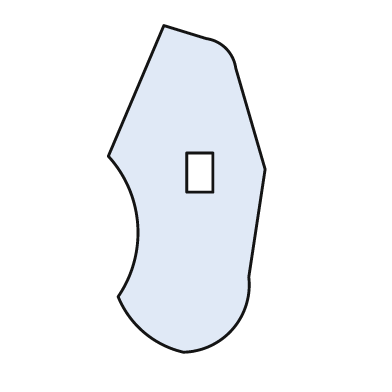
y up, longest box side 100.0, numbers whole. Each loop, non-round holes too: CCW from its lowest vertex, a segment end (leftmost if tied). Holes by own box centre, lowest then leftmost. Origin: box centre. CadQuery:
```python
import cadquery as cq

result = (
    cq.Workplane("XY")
    .moveTo(-1.0, -50.0)
    .threePointArc((14.0, -43.0), (19.0, -27.0))
    .lineTo(24.0, 6.0)
    .lineTo(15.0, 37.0)
    .threePointArc((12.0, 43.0), (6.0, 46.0))
    .lineTo(-7.0, 50.0)
    .lineTo(-24.0, 10.0)
    .threePointArc((-15.0, -11.0), (-21.0, -33.0))
    .threePointArc((-13.0, -44.0), (-1.0, -50.0))
    .close()
    .moveTo(0.0, -1.0)
    .lineTo(8.0, -1.0)
    .lineTo(8.0, 11.0)
    .lineTo(0.0, 11.0)
    .close()
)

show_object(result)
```